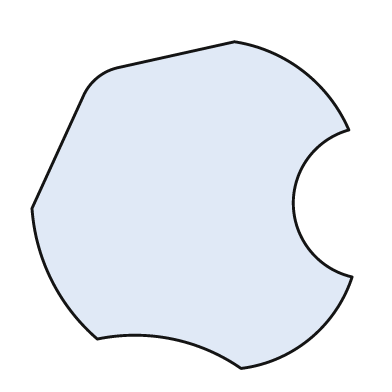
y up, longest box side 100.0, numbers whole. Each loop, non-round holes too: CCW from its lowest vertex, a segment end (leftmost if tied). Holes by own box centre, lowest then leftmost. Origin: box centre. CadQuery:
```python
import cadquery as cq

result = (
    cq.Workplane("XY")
    .moveTo(15.0, -50.0)
    .threePointArc((36.0, -41.0), (49.0, -22.0))
    .threePointArc((31.0, 0.0), (48.0, 23.0))
    .threePointArc((34.0, 41.0), (13.0, 50.0))
    .lineTo(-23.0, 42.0)
    .threePointArc((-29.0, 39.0), (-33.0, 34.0))
    .lineTo(-49.0, -1.0)
    .threePointArc((-43.0, -23.0), (-29.0, -41.0))
    .threePointArc((-6.0, -41.0), (15.0, -50.0))
    .close()
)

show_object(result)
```